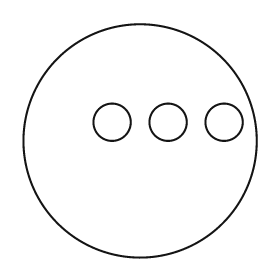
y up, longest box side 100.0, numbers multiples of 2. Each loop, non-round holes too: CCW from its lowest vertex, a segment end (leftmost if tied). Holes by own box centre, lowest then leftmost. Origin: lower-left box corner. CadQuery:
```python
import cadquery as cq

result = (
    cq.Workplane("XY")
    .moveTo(50.0, 50.0)
    .circle(50.0)
    .moveTo(38.0, 58.0)
    .circle(8.0)
    .moveTo(62.0, 58.0)
    .circle(8.0)
    .moveTo(86.0, 58.0)
    .circle(8.0)
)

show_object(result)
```